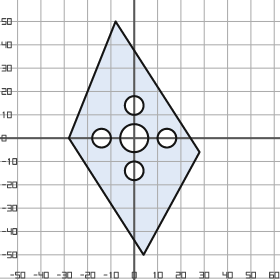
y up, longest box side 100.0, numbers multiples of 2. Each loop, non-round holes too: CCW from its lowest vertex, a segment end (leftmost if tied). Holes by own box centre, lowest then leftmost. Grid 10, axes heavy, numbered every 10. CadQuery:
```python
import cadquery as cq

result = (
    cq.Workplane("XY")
    .moveTo(4.0, -50.0)
    .lineTo(28.0, -6.0)
    .lineTo(-8.0, 50.0)
    .lineTo(-28.0, 0.0)
    .close()
    .moveTo(0.0, -14.0)
    .circle(4.0)
    .moveTo(-14.0, 0.0)
    .circle(4.0)
    .moveTo(0.0, 0.0)
    .circle(6.0)
    .moveTo(14.0, 0.0)
    .circle(4.0)
    .moveTo(0.0, 14.0)
    .circle(4.0)
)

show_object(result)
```